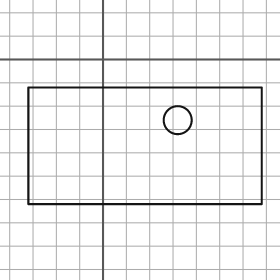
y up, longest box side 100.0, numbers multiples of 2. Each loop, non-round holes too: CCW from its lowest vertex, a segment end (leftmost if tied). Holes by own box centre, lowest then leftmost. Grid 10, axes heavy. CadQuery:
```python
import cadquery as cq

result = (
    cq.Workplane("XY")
    .moveTo(-32.0, -62.0)
    .lineTo(68.0, -62.0)
    .lineTo(68.0, -12.0)
    .lineTo(-32.0, -12.0)
    .close()
    .moveTo(32.0, -26.0)
    .circle(6.0)
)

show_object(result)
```